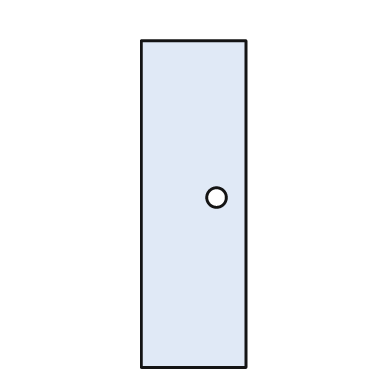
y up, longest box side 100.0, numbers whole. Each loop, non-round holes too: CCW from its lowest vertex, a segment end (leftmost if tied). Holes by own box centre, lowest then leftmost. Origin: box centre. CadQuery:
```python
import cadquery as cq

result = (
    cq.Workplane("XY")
    .moveTo(-16.0, -50.0)
    .lineTo(16.0, -50.0)
    .lineTo(16.0, 50.0)
    .lineTo(-16.0, 50.0)
    .close()
    .moveTo(7.0, 2.0)
    .circle(3.0)
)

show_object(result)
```